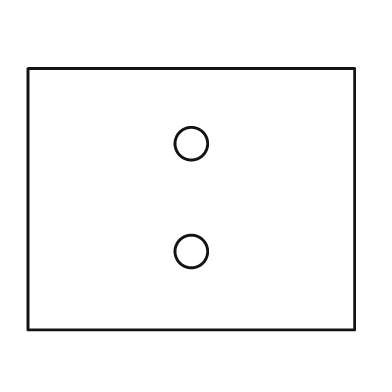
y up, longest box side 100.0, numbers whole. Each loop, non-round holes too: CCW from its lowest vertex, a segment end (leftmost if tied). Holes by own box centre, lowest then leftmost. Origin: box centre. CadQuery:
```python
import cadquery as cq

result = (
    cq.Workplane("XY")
    .moveTo(-50.0, -40.0)
    .lineTo(50.0, -40.0)
    .lineTo(50.0, 40.0)
    .lineTo(-50.0, 40.0)
    .close()
    .moveTo(0.0, -16.0)
    .circle(5.0)
    .moveTo(0.0, 17.0)
    .circle(5.0)
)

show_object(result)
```